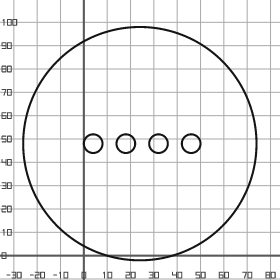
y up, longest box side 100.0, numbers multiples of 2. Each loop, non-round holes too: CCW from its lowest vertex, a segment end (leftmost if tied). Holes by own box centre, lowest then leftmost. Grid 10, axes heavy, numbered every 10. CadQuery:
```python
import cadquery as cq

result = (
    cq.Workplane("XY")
    .moveTo(24.0, 48.0)
    .circle(50.0)
    .moveTo(4.0, 48.0)
    .circle(4.0)
    .moveTo(18.0, 48.0)
    .circle(4.0)
    .moveTo(32.0, 48.0)
    .circle(4.0)
    .moveTo(46.0, 48.0)
    .circle(4.0)
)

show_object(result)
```